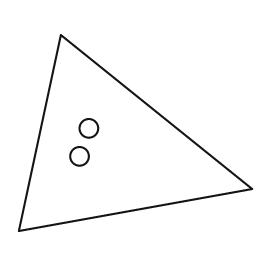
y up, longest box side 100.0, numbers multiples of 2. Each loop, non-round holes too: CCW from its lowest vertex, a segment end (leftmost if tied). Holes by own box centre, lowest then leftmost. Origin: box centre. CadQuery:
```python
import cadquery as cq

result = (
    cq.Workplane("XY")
    .moveTo(-50.0, -42.0)
    .lineTo(50.0, -24.0)
    .lineTo(-32.0, 42.0)
    .close()
    .moveTo(-24.0, -10.0)
    .circle(4.0)
    .moveTo(-20.0, 2.0)
    .circle(4.0)
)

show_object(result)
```